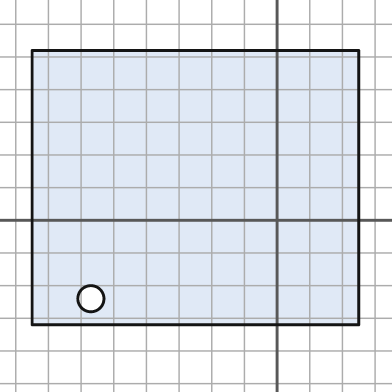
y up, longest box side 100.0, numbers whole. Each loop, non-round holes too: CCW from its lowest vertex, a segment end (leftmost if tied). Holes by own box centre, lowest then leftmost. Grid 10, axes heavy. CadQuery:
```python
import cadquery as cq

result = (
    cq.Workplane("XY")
    .moveTo(-75.0, -32.0)
    .lineTo(25.0, -32.0)
    .lineTo(25.0, 52.0)
    .lineTo(-75.0, 52.0)
    .close()
    .moveTo(-57.0, -24.0)
    .circle(4.0)
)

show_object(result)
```